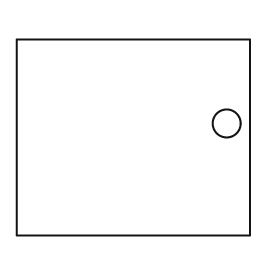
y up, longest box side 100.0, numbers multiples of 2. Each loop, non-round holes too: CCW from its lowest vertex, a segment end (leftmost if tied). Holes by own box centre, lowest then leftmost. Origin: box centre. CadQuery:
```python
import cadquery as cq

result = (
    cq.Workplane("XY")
    .moveTo(-50.0, -42.0)
    .lineTo(50.0, -42.0)
    .lineTo(50.0, 42.0)
    .lineTo(-50.0, 42.0)
    .close()
    .moveTo(40.0, 6.0)
    .circle(6.0)
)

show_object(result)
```